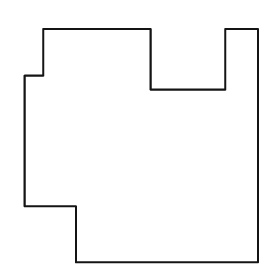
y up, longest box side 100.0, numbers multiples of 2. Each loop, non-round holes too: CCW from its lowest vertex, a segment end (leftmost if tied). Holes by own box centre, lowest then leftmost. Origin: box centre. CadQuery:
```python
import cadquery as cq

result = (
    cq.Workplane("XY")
    .moveTo(-28.0, -50.0)
    .lineTo(50.0, -50.0)
    .lineTo(50.0, 50.0)
    .lineTo(36.0, 50.0)
    .lineTo(36.0, 24.0)
    .lineTo(4.0, 24.0)
    .lineTo(4.0, 50.0)
    .lineTo(-42.0, 50.0)
    .lineTo(-42.0, 30.0)
    .lineTo(-50.0, 30.0)
    .lineTo(-50.0, -26.0)
    .lineTo(-28.0, -26.0)
    .close()
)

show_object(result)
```